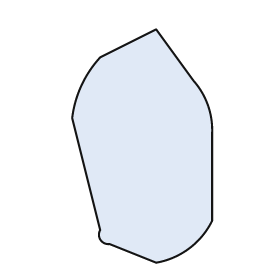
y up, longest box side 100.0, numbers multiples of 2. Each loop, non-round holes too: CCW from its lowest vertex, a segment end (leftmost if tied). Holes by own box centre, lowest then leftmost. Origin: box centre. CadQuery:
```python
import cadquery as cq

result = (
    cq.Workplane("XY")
    .moveTo(6.0, -50.0)
    .threePointArc((20.0, -44.0), (30.0, -32.0))
    .lineTo(30.0, 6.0)
    .threePointArc((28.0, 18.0), (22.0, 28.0))
    .lineTo(6.0, 50.0)
    .lineTo(-18.0, 38.0)
    .threePointArc((-26.0, 26.0), (-30.0, 12.0))
    .lineTo(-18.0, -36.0)
    .threePointArc((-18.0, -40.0), (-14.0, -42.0))
    .close()
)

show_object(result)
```